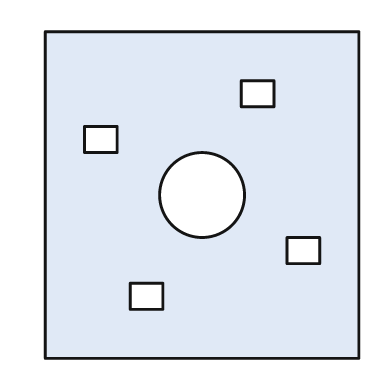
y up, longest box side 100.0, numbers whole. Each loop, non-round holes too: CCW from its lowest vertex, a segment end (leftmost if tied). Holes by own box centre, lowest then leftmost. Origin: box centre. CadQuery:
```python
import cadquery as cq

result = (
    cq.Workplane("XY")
    .moveTo(-48.0, -50.0)
    .lineTo(48.0, -50.0)
    .lineTo(48.0, 50.0)
    .lineTo(-48.0, 50.0)
    .close()
    .moveTo(-22.0, -35.0)
    .lineTo(-12.0, -35.0)
    .lineTo(-12.0, -27.0)
    .lineTo(-22.0, -27.0)
    .close()
    .moveTo(26.0, -21.0)
    .lineTo(36.0, -21.0)
    .lineTo(36.0, -13.0)
    .lineTo(26.0, -13.0)
    .close()
    .moveTo(0.0, 0.0)
    .circle(13.0)
    .moveTo(-36.0, 13.0)
    .lineTo(-26.0, 13.0)
    .lineTo(-26.0, 21.0)
    .lineTo(-36.0, 21.0)
    .close()
    .moveTo(12.0, 27.0)
    .lineTo(22.0, 27.0)
    .lineTo(22.0, 35.0)
    .lineTo(12.0, 35.0)
    .close()
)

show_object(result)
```